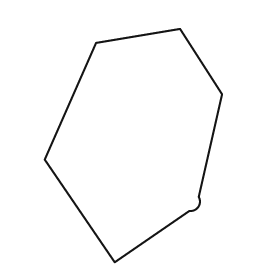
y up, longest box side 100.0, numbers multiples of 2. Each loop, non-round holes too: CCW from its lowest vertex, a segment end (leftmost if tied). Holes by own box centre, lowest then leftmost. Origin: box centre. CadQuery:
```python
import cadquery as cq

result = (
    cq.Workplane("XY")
    .moveTo(-8.0, -50.0)
    .lineTo(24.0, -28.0)
    .threePointArc((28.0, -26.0), (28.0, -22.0))
    .lineTo(38.0, 22.0)
    .lineTo(20.0, 50.0)
    .lineTo(-16.0, 44.0)
    .lineTo(-38.0, -6.0)
    .close()
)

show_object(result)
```